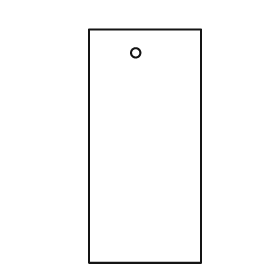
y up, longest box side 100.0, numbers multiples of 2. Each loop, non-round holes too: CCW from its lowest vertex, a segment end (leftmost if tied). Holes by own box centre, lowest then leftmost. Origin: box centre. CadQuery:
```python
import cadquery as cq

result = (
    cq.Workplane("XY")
    .moveTo(-24.0, -50.0)
    .lineTo(24.0, -50.0)
    .lineTo(24.0, 50.0)
    .lineTo(-24.0, 50.0)
    .close()
    .moveTo(-4.0, 40.0)
    .circle(2.0)
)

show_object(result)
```